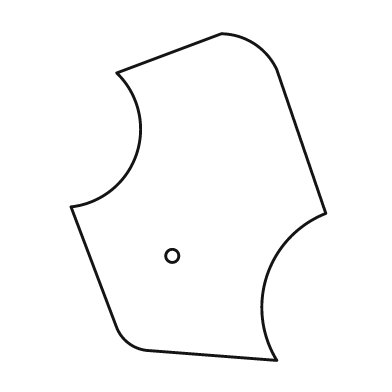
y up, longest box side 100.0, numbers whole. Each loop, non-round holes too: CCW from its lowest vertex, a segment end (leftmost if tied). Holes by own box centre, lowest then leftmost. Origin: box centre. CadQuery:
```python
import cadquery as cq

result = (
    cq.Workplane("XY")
    .moveTo(24.0, -50.0)
    .threePointArc((21.0, -24.0), (39.0, -5.0))
    .lineTo(24.0, 39.0)
    .threePointArc((17.0, 47.0), (7.0, 50.0))
    .lineTo(-25.0, 38.0)
    .threePointArc((-19.0, 13.0), (-39.0, -3.0))
    .lineTo(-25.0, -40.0)
    .threePointArc((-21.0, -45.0), (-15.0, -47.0))
    .close()
    .moveTo(-8.0, -18.0)
    .circle(2.0)
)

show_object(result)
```